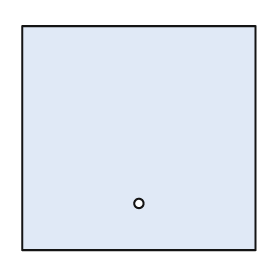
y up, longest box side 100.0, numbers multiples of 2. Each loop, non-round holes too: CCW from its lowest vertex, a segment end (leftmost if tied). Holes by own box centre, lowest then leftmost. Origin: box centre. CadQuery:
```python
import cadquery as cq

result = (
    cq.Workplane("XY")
    .moveTo(-50.0, -48.0)
    .lineTo(50.0, -48.0)
    .lineTo(50.0, 48.0)
    .lineTo(-50.0, 48.0)
    .close()
    .moveTo(0.0, -28.0)
    .circle(2.0)
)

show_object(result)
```